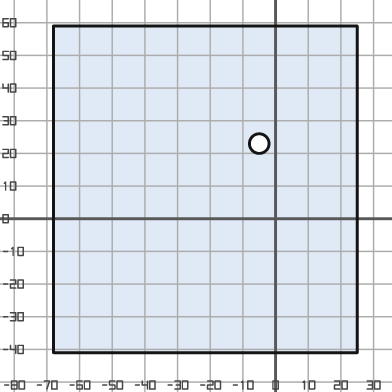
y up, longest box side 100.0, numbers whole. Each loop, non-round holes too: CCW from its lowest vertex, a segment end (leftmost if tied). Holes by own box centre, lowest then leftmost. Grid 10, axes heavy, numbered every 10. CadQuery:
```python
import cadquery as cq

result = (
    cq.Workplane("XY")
    .moveTo(-68.0, -41.0)
    .lineTo(25.0, -41.0)
    .lineTo(25.0, 59.0)
    .lineTo(-68.0, 59.0)
    .close()
    .moveTo(-5.0, 23.0)
    .circle(3.0)
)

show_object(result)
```